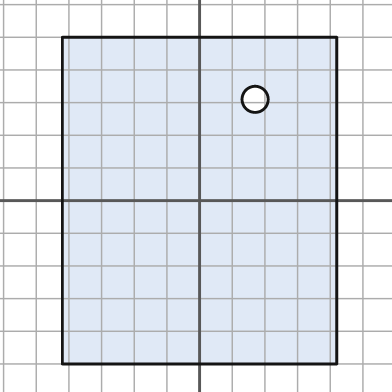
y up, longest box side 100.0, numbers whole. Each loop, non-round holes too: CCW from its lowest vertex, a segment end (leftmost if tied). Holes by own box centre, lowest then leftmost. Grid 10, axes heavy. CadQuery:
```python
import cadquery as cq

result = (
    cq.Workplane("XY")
    .moveTo(-42.0, -50.0)
    .lineTo(42.0, -50.0)
    .lineTo(42.0, 50.0)
    .lineTo(-42.0, 50.0)
    .close()
    .moveTo(17.0, 31.0)
    .circle(4.0)
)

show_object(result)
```